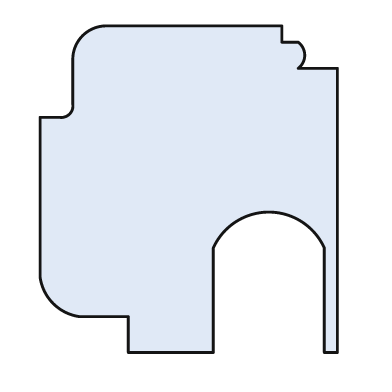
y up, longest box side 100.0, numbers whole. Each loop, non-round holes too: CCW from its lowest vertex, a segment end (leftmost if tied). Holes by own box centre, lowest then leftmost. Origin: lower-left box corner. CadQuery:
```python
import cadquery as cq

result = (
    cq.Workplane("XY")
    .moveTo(27.0, 0.0)
    .lineTo(53.0, 0.0)
    .lineTo(53.0, 32.0)
    .threePointArc((70.0, 43.0), (87.0, 32.0))
    .lineTo(87.0, 0.0)
    .lineTo(91.0, 0.0)
    .lineTo(91.0, 87.0)
    .lineTo(79.0, 87.0)
    .threePointArc((81.0, 91.0), (79.0, 95.0))
    .lineTo(74.0, 95.0)
    .lineTo(74.0, 100.0)
    .lineTo(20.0, 100.0)
    .threePointArc((13.0, 97.0), (10.0, 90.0))
    .lineTo(10.0, 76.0)
    .threePointArc((9.0, 73.0), (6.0, 72.0))
    .lineTo(0.0, 72.0)
    .lineTo(0.0, 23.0)
    .threePointArc((4.0, 15.0), (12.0, 11.0))
    .lineTo(27.0, 11.0)
    .close()
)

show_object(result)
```